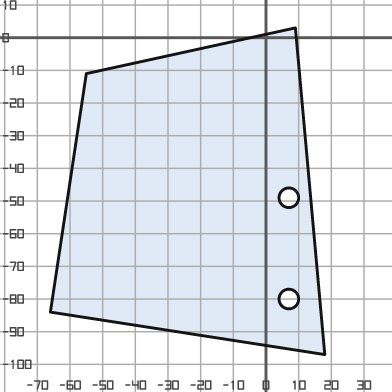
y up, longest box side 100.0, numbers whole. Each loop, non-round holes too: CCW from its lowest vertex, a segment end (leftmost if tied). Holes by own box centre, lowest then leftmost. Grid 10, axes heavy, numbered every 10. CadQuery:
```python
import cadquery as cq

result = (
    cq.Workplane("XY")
    .moveTo(18.0, -97.0)
    .lineTo(9.0, 3.0)
    .lineTo(-55.0, -11.0)
    .lineTo(-66.0, -84.0)
    .close()
    .moveTo(7.0, -80.0)
    .circle(3.0)
    .moveTo(7.0, -49.0)
    .circle(3.0)
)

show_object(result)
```